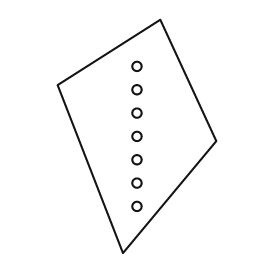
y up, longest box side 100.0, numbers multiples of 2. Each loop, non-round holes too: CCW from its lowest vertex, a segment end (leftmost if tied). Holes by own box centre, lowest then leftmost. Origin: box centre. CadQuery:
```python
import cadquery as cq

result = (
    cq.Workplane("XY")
    .moveTo(-6.0, -50.0)
    .lineTo(34.0, -2.0)
    .lineTo(10.0, 50.0)
    .lineTo(-34.0, 22.0)
    .close()
    .moveTo(0.0, -30.0)
    .circle(2.0)
    .moveTo(0.0, -20.0)
    .circle(2.0)
    .moveTo(0.0, -10.0)
    .circle(2.0)
    .moveTo(0.0, 0.0)
    .circle(2.0)
    .moveTo(0.0, 10.0)
    .circle(2.0)
    .moveTo(0.0, 20.0)
    .circle(2.0)
    .moveTo(0.0, 30.0)
    .circle(2.0)
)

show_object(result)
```